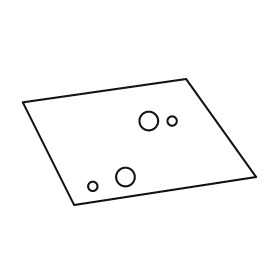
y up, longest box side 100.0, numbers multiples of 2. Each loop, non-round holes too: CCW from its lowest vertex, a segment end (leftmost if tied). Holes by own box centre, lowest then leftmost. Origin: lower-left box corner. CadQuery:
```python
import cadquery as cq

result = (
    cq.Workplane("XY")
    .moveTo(22.0, 0.0)
    .lineTo(100.0, 12.0)
    .lineTo(70.0, 54.0)
    .lineTo(0.0, 44.0)
    .close()
    .moveTo(30.0, 8.0)
    .circle(2.0)
    .moveTo(44.0, 12.0)
    .circle(4.0)
    .moveTo(54.0, 36.0)
    .circle(4.0)
    .moveTo(64.0, 36.0)
    .circle(2.0)
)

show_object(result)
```